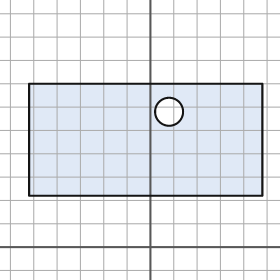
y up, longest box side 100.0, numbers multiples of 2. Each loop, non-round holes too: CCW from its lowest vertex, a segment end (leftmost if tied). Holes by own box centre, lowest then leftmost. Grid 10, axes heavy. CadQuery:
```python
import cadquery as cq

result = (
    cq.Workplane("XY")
    .moveTo(-52.0, 22.0)
    .lineTo(48.0, 22.0)
    .lineTo(48.0, 70.0)
    .lineTo(-52.0, 70.0)
    .close()
    .moveTo(8.0, 58.0)
    .circle(6.0)
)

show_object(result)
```